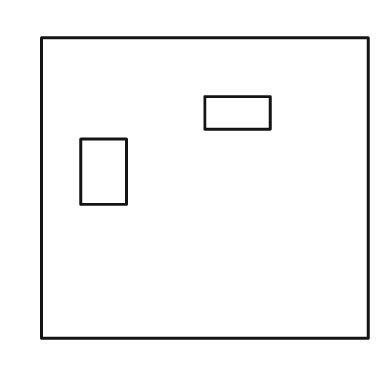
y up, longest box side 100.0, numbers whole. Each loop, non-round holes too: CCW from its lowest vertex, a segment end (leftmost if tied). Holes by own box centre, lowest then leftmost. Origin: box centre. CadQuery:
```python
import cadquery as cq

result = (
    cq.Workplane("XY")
    .moveTo(-50.0, -46.0)
    .lineTo(50.0, -46.0)
    .lineTo(50.0, 46.0)
    .lineTo(-50.0, 46.0)
    .close()
    .moveTo(-38.0, -5.0)
    .lineTo(-24.0, -5.0)
    .lineTo(-24.0, 15.0)
    .lineTo(-38.0, 15.0)
    .close()
    .moveTo(0.0, 18.0)
    .lineTo(20.0, 18.0)
    .lineTo(20.0, 28.0)
    .lineTo(0.0, 28.0)
    .close()
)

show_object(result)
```